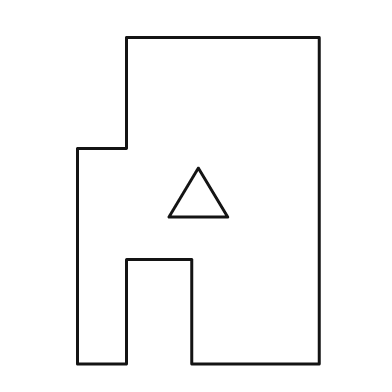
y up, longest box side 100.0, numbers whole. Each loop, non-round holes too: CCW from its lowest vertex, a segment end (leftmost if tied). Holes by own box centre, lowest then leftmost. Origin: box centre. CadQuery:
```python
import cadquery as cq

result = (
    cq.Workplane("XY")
    .moveTo(-37.0, -50.0)
    .lineTo(-22.0, -50.0)
    .lineTo(-22.0, -18.0)
    .lineTo(-2.0, -18.0)
    .lineTo(-2.0, -50.0)
    .lineTo(37.0, -50.0)
    .lineTo(37.0, 50.0)
    .lineTo(-22.0, 50.0)
    .lineTo(-22.0, 16.0)
    .lineTo(-37.0, 16.0)
    .close()
    .moveTo(-9.0, -5.0)
    .lineTo(9.0, -5.0)
    .lineTo(0.0, 10.0)
    .close()
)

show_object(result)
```